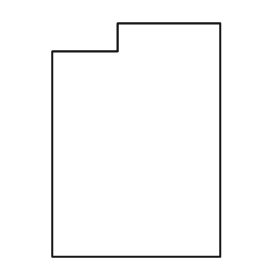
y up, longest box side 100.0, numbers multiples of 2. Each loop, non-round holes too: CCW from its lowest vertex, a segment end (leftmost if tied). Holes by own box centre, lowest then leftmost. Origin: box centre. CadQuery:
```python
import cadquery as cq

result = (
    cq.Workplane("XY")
    .moveTo(-36.0, -50.0)
    .lineTo(36.0, -50.0)
    .lineTo(36.0, 50.0)
    .lineTo(-8.0, 50.0)
    .lineTo(-8.0, 38.0)
    .lineTo(-36.0, 38.0)
    .close()
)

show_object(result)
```